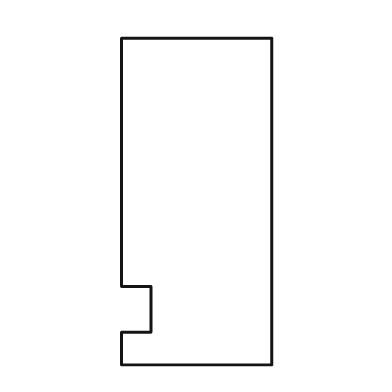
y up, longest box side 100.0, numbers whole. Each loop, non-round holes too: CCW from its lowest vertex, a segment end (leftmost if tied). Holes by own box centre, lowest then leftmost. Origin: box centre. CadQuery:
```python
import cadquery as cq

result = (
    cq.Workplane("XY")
    .moveTo(-23.0, -50.0)
    .lineTo(23.0, -50.0)
    .lineTo(23.0, 50.0)
    .lineTo(-23.0, 50.0)
    .lineTo(-23.0, -26.0)
    .lineTo(-14.0, -26.0)
    .lineTo(-14.0, -40.0)
    .lineTo(-23.0, -40.0)
    .close()
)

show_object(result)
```